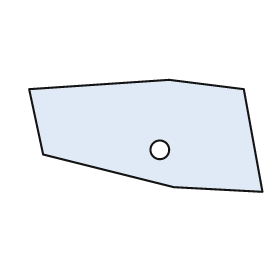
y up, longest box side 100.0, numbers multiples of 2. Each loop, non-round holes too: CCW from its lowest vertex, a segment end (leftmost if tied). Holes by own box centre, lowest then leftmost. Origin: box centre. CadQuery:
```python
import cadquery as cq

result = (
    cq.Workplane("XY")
    .moveTo(50.0, -24.0)
    .lineTo(42.0, 20.0)
    .lineTo(10.0, 24.0)
    .lineTo(-50.0, 20.0)
    .lineTo(-44.0, -8.0)
    .lineTo(12.0, -22.0)
    .close()
    .moveTo(6.0, -6.0)
    .circle(4.0)
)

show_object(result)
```